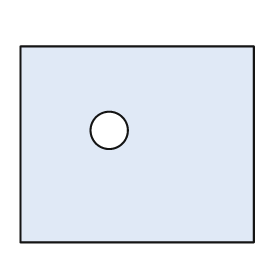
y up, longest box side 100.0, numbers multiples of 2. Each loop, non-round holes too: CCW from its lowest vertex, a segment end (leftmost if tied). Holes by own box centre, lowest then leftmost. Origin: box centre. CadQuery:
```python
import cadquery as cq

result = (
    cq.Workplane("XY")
    .moveTo(-50.0, -42.0)
    .lineTo(50.0, -42.0)
    .lineTo(50.0, 42.0)
    .lineTo(-50.0, 42.0)
    .close()
    .moveTo(-12.0, 6.0)
    .circle(8.0)
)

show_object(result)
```